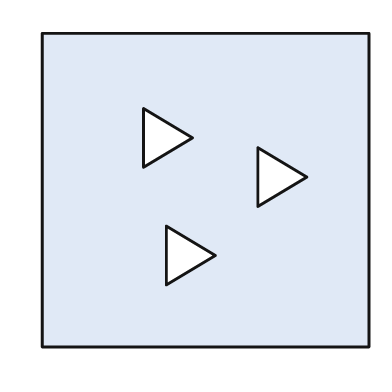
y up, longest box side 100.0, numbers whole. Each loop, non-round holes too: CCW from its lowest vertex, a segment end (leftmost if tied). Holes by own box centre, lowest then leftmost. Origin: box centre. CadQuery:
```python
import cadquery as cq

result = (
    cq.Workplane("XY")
    .moveTo(-50.0, -48.0)
    .lineTo(50.0, -48.0)
    .lineTo(50.0, 48.0)
    .lineTo(-50.0, 48.0)
    .close()
    .moveTo(-12.0, -29.0)
    .lineTo(3.0, -20.0)
    .lineTo(-12.0, -11.0)
    .close()
    .moveTo(16.0, -5.0)
    .lineTo(31.0, 4.0)
    .lineTo(16.0, 13.0)
    .close()
    .moveTo(-19.0, 7.0)
    .lineTo(-4.0, 16.0)
    .lineTo(-19.0, 25.0)
    .close()
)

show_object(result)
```